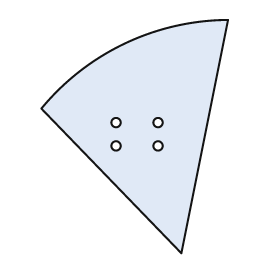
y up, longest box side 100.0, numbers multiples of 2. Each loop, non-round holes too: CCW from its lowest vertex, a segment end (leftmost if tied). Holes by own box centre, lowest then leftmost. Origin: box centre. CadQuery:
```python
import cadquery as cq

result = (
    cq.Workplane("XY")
    .moveTo(20.0, -50.0)
    .lineTo(40.0, 50.0)
    .threePointArc((-4.0, 40.0), (-40.0, 12.0))
    .close()
    .moveTo(-8.0, -4.0)
    .circle(2.0)
    .moveTo(10.0, -4.0)
    .circle(2.0)
    .moveTo(-8.0, 6.0)
    .circle(2.0)
    .moveTo(10.0, 6.0)
    .circle(2.0)
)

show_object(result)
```